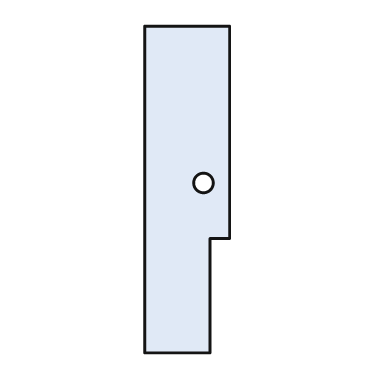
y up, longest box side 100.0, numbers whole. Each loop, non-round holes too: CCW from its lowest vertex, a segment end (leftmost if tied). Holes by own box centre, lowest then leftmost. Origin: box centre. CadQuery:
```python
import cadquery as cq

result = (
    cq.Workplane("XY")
    .moveTo(-13.0, -50.0)
    .lineTo(7.0, -50.0)
    .lineTo(7.0, -15.0)
    .lineTo(13.0, -15.0)
    .lineTo(13.0, 50.0)
    .lineTo(-13.0, 50.0)
    .close()
    .moveTo(5.0, 2.0)
    .circle(3.0)
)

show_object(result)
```